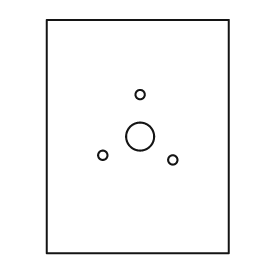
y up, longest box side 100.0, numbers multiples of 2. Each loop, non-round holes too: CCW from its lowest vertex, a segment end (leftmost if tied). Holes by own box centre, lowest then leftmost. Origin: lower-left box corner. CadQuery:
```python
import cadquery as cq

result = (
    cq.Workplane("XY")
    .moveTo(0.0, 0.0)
    .lineTo(78.0, 0.0)
    .lineTo(78.0, 100.0)
    .lineTo(0.0, 100.0)
    .close()
    .moveTo(54.0, 40.0)
    .circle(2.0)
    .moveTo(24.0, 42.0)
    .circle(2.0)
    .moveTo(40.0, 50.0)
    .circle(6.0)
    .moveTo(40.0, 68.0)
    .circle(2.0)
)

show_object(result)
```